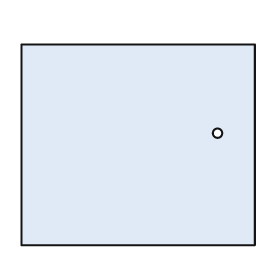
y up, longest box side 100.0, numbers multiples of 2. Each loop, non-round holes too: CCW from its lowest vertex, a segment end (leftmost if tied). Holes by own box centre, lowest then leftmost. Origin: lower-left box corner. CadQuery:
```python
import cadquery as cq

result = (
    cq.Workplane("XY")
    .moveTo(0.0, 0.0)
    .lineTo(100.0, 0.0)
    .lineTo(100.0, 86.0)
    .lineTo(0.0, 86.0)
    .close()
    .moveTo(84.0, 48.0)
    .circle(2.0)
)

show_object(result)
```